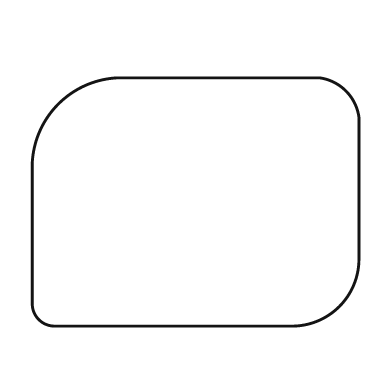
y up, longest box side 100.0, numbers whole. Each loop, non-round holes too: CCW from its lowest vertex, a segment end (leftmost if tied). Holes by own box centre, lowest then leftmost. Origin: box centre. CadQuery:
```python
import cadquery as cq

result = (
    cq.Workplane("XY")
    .moveTo(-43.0, -38.0)
    .lineTo(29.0, -38.0)
    .threePointArc((44.0, -32.0), (50.0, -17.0))
    .lineTo(50.0, 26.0)
    .threePointArc((46.0, 34.0), (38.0, 38.0))
    .lineTo(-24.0, 38.0)
    .threePointArc((-42.0, 30.0), (-50.0, 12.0))
    .lineTo(-50.0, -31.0)
    .threePointArc((-48.0, -36.0), (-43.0, -38.0))
    .close()
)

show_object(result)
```